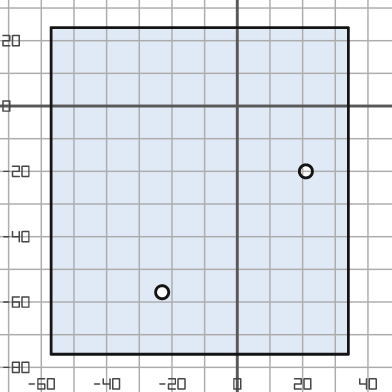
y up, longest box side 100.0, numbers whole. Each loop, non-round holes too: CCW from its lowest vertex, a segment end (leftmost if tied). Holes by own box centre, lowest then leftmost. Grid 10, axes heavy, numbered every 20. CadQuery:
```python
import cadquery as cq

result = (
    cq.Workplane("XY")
    .moveTo(-57.0, -76.0)
    .lineTo(34.0, -76.0)
    .lineTo(34.0, 24.0)
    .lineTo(-57.0, 24.0)
    .close()
    .moveTo(-23.0, -57.0)
    .circle(2.0)
    .moveTo(21.0, -20.0)
    .circle(2.0)
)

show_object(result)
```